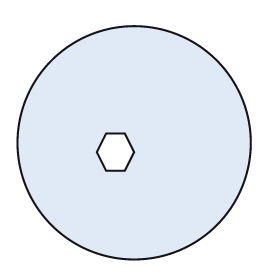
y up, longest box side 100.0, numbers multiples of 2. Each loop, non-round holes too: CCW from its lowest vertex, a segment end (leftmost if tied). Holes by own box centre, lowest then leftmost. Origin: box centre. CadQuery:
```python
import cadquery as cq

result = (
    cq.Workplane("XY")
    .moveTo(0.0, 0.0)
    .circle(50.0)
    .moveTo(-12.0, -12.0)
    .lineTo(-4.0, -12.0)
    .lineTo(0.0, -4.0)
    .lineTo(-4.0, 4.0)
    .lineTo(-12.0, 4.0)
    .lineTo(-16.0, -4.0)
    .close()
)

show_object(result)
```